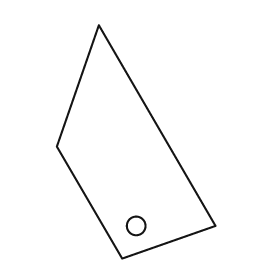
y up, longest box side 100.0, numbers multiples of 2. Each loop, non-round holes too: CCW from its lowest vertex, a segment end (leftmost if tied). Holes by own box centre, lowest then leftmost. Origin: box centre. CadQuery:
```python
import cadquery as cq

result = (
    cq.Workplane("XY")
    .moveTo(-6.0, -50.0)
    .lineTo(34.0, -36.0)
    .lineTo(-16.0, 50.0)
    .lineTo(-34.0, -2.0)
    .close()
    .moveTo(0.0, -36.0)
    .circle(4.0)
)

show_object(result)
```